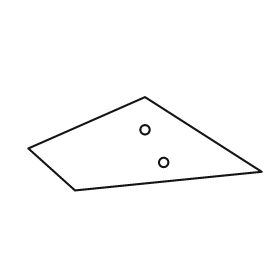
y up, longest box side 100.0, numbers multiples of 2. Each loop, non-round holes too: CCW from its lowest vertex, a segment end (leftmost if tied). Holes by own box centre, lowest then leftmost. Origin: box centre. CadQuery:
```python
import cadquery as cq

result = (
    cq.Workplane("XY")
    .moveTo(-30.0, -20.0)
    .lineTo(50.0, -12.0)
    .lineTo(0.0, 20.0)
    .lineTo(-50.0, -2.0)
    .close()
    .moveTo(8.0, -8.0)
    .circle(2.0)
    .moveTo(0.0, 6.0)
    .circle(2.0)
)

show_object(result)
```